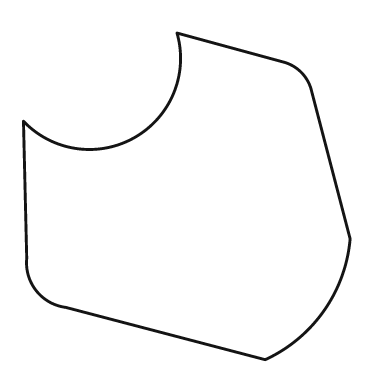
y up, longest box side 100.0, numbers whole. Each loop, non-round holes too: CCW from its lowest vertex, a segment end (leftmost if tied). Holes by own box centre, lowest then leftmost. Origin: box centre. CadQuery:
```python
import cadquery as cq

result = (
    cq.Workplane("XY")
    .moveTo(24.0, -50.0)
    .threePointArc((42.0, -35.0), (50.0, -13.0))
    .lineTo(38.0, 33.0)
    .threePointArc((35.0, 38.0), (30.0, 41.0))
    .lineTo(-3.0, 50.0)
    .threePointArc((-16.0, 18.0), (-50.0, 23.0))
    .lineTo(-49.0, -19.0)
    .threePointArc((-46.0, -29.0), (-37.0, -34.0))
    .close()
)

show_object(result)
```